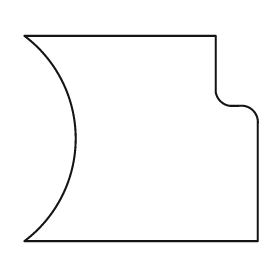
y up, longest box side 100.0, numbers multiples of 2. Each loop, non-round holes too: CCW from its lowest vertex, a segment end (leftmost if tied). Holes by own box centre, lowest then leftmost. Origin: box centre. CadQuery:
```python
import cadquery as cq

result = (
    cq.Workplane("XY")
    .moveTo(-50.0, -44.0)
    .lineTo(50.0, -44.0)
    .lineTo(50.0, 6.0)
    .threePointArc((48.0, 12.0), (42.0, 14.0))
    .lineTo(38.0, 14.0)
    .threePointArc((34.0, 16.0), (32.0, 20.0))
    .lineTo(32.0, 44.0)
    .lineTo(-50.0, 44.0)
    .threePointArc((-28.0, 0.0), (-50.0, -44.0))
    .close()
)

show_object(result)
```